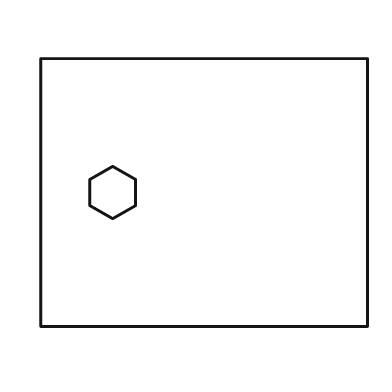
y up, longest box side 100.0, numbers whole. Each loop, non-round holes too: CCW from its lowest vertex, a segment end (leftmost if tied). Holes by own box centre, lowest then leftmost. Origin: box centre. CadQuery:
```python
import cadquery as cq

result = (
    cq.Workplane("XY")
    .moveTo(-50.0, -41.0)
    .lineTo(50.0, -41.0)
    .lineTo(50.0, 41.0)
    .lineTo(-50.0, 41.0)
    .close()
    .moveTo(-28.0, -8.0)
    .lineTo(-21.0, -4.0)
    .lineTo(-21.0, 4.0)
    .lineTo(-28.0, 8.0)
    .lineTo(-35.0, 4.0)
    .lineTo(-35.0, -4.0)
    .close()
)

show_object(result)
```